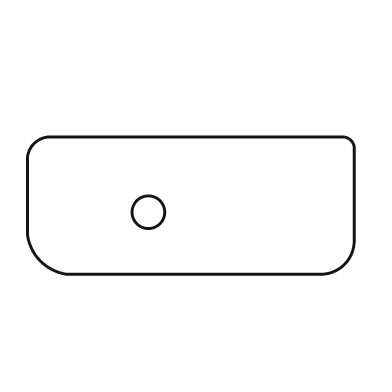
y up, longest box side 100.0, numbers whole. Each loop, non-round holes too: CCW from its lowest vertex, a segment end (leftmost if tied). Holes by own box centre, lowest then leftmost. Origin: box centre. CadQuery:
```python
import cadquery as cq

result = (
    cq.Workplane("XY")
    .moveTo(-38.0, -21.0)
    .lineTo(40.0, -21.0)
    .threePointArc((47.0, -18.0), (50.0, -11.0))
    .lineTo(50.0, 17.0)
    .threePointArc((49.0, 20.0), (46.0, 21.0))
    .lineTo(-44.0, 21.0)
    .threePointArc((-48.0, 19.0), (-50.0, 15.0))
    .lineTo(-50.0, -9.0)
    .threePointArc((-46.0, -17.0), (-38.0, -21.0))
    .close()
    .moveTo(-13.0, -2.0)
    .circle(5.0)
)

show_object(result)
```